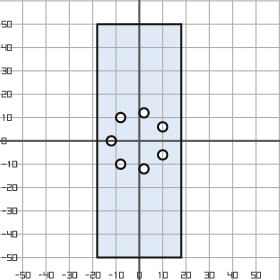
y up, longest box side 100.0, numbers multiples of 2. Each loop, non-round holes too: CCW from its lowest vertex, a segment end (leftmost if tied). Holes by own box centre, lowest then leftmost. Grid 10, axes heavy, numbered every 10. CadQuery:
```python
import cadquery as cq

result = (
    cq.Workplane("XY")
    .moveTo(-18.0, -50.0)
    .lineTo(18.0, -50.0)
    .lineTo(18.0, 50.0)
    .lineTo(-18.0, 50.0)
    .close()
    .moveTo(2.0, -12.0)
    .circle(2.0)
    .moveTo(-8.0, -10.0)
    .circle(2.0)
    .moveTo(10.0, -6.0)
    .circle(2.0)
    .moveTo(-12.0, 0.0)
    .circle(2.0)
    .moveTo(10.0, 6.0)
    .circle(2.0)
    .moveTo(-8.0, 10.0)
    .circle(2.0)
    .moveTo(2.0, 12.0)
    .circle(2.0)
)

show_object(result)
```